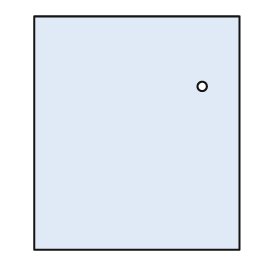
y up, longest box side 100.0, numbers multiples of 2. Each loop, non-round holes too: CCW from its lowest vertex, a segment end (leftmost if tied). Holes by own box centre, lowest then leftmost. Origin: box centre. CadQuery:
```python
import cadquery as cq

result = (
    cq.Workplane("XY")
    .moveTo(-44.0, -50.0)
    .lineTo(44.0, -50.0)
    .lineTo(44.0, 50.0)
    .lineTo(-44.0, 50.0)
    .close()
    .moveTo(28.0, 20.0)
    .circle(2.0)
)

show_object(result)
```